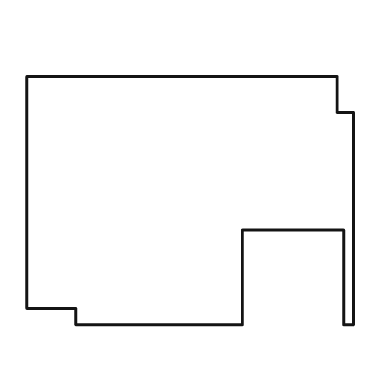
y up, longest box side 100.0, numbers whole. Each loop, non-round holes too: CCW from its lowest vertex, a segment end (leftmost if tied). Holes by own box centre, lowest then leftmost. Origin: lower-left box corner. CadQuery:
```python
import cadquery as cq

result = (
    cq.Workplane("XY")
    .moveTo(15.0, 0.0)
    .lineTo(66.0, 0.0)
    .lineTo(66.0, 29.0)
    .lineTo(97.0, 29.0)
    .lineTo(97.0, 0.0)
    .lineTo(100.0, 0.0)
    .lineTo(100.0, 65.0)
    .lineTo(95.0, 65.0)
    .lineTo(95.0, 76.0)
    .lineTo(0.0, 76.0)
    .lineTo(0.0, 5.0)
    .lineTo(15.0, 5.0)
    .close()
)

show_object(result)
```